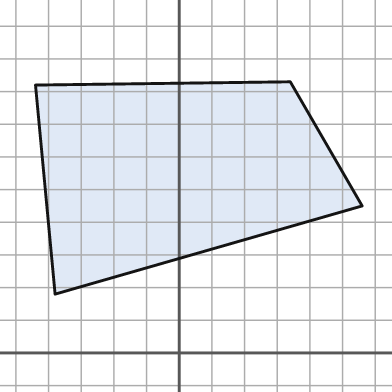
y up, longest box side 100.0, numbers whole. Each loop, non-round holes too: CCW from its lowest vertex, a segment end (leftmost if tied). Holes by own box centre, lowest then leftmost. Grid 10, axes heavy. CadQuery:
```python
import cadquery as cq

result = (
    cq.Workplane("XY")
    .moveTo(-38.0, 18.0)
    .lineTo(56.0, 45.0)
    .lineTo(34.0, 83.0)
    .lineTo(-44.0, 82.0)
    .close()
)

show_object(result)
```